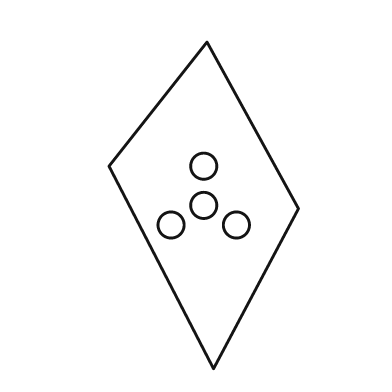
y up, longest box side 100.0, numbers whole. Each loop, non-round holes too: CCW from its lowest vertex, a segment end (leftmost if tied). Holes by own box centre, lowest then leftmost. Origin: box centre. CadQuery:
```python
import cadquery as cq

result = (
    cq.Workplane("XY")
    .moveTo(3.0, -50.0)
    .lineTo(29.0, -1.0)
    .lineTo(1.0, 50.0)
    .lineTo(-29.0, 12.0)
    .close()
    .moveTo(-10.0, -6.0)
    .circle(4.0)
    .moveTo(10.0, -6.0)
    .circle(4.0)
    .moveTo(0.0, 0.0)
    .circle(4.0)
    .moveTo(0.0, 12.0)
    .circle(4.0)
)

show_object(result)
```